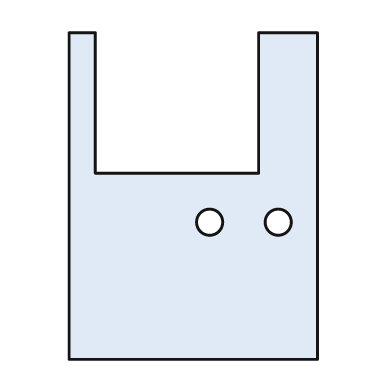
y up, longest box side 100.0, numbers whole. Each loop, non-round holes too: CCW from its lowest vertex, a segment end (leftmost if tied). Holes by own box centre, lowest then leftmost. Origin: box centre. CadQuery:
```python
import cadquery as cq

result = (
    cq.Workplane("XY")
    .moveTo(-38.0, -50.0)
    .lineTo(38.0, -50.0)
    .lineTo(38.0, 50.0)
    .lineTo(20.0, 50.0)
    .lineTo(20.0, 7.0)
    .lineTo(-30.0, 7.0)
    .lineTo(-30.0, 50.0)
    .lineTo(-38.0, 50.0)
    .close()
    .moveTo(5.0, -8.0)
    .circle(4.0)
    .moveTo(26.0, -8.0)
    .circle(4.0)
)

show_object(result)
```